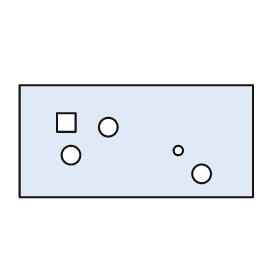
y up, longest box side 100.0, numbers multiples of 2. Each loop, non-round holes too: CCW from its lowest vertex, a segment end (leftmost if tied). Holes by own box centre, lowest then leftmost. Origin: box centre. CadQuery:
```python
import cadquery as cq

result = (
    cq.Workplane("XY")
    .moveTo(-50.0, -24.0)
    .lineTo(50.0, -24.0)
    .lineTo(50.0, 24.0)
    .lineTo(-50.0, 24.0)
    .close()
    .moveTo(28.0, -14.0)
    .circle(4.0)
    .moveTo(-28.0, -6.0)
    .circle(4.0)
    .moveTo(18.0, -4.0)
    .circle(2.0)
    .moveTo(-12.0, 6.0)
    .circle(4.0)
    .moveTo(-34.0, 4.0)
    .lineTo(-26.0, 4.0)
    .lineTo(-26.0, 12.0)
    .lineTo(-34.0, 12.0)
    .close()
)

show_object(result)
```